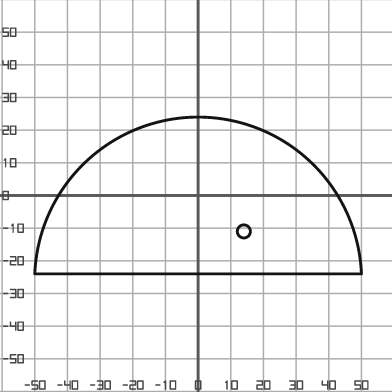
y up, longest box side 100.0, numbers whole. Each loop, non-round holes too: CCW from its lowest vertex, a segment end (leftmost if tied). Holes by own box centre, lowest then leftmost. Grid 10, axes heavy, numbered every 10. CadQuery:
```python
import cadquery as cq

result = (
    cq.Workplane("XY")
    .moveTo(-50.0, -24.0)
    .lineTo(50.0, -24.0)
    .threePointArc((0.0, 24.0), (-50.0, -24.0))
    .close()
    .moveTo(14.0, -11.0)
    .circle(2.0)
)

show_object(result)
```